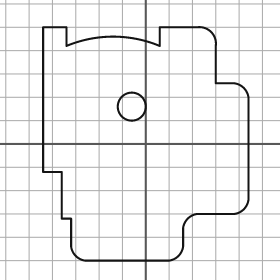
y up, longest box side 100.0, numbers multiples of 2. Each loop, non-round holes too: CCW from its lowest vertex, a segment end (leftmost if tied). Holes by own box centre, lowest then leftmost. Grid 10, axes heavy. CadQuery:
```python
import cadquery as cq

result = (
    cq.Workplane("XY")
    .moveTo(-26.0, -50.0)
    .lineTo(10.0, -50.0)
    .threePointArc((14.0, -48.0), (16.0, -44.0))
    .lineTo(16.0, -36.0)
    .threePointArc((18.0, -32.0), (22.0, -30.0))
    .lineTo(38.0, -30.0)
    .threePointArc((42.0, -28.0), (44.0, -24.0))
    .lineTo(44.0, 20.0)
    .threePointArc((42.0, 24.0), (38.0, 26.0))
    .lineTo(30.0, 26.0)
    .lineTo(30.0, 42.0)
    .threePointArc((28.0, 48.0), (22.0, 50.0))
    .lineTo(6.0, 50.0)
    .lineTo(6.0, 42.0)
    .threePointArc((-14.0, 46.0), (-34.0, 42.0))
    .lineTo(-34.0, 50.0)
    .lineTo(-44.0, 50.0)
    .lineTo(-44.0, -12.0)
    .lineTo(-36.0, -12.0)
    .lineTo(-36.0, -32.0)
    .lineTo(-32.0, -32.0)
    .lineTo(-32.0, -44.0)
    .threePointArc((-30.0, -48.0), (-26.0, -50.0))
    .close()
    .moveTo(-6.0, 16.0)
    .circle(6.0)
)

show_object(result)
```